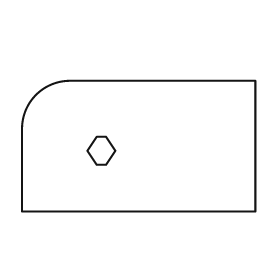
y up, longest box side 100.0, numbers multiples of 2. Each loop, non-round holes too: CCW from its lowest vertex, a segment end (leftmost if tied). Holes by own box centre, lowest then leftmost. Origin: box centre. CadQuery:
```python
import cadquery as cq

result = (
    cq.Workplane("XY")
    .moveTo(-50.0, -28.0)
    .lineTo(50.0, -28.0)
    .lineTo(50.0, 28.0)
    .lineTo(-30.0, 28.0)
    .threePointArc((-44.0, 22.0), (-50.0, 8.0))
    .close()
    .moveTo(-18.0, -8.0)
    .lineTo(-14.0, -8.0)
    .lineTo(-10.0, -2.0)
    .lineTo(-14.0, 4.0)
    .lineTo(-18.0, 4.0)
    .lineTo(-22.0, -2.0)
    .close()
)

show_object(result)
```